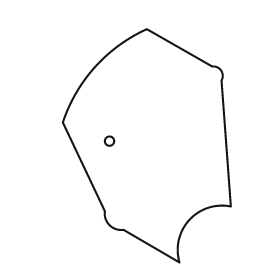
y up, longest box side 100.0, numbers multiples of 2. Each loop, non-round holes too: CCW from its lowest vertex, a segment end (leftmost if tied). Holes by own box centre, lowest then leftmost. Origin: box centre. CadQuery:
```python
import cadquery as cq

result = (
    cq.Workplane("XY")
    .moveTo(14.0, -50.0)
    .threePointArc((18.0, -32.0), (36.0, -26.0))
    .lineTo(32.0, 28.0)
    .threePointArc((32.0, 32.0), (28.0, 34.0))
    .lineTo(0.0, 50.0)
    .threePointArc((-22.0, 34.0), (-36.0, 10.0))
    .lineTo(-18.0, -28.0)
    .threePointArc((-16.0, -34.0), (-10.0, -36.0))
    .close()
    .moveTo(-16.0, 2.0)
    .circle(2.0)
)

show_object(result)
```